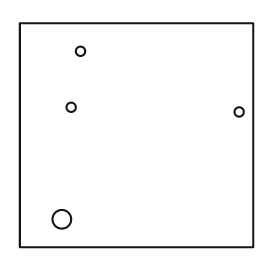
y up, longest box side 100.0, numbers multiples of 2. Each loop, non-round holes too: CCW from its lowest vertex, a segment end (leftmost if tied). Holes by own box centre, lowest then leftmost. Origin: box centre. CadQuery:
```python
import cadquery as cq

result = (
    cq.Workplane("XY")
    .moveTo(-50.0, -48.0)
    .lineTo(50.0, -48.0)
    .lineTo(50.0, 48.0)
    .lineTo(-50.0, 48.0)
    .close()
    .moveTo(-32.0, -36.0)
    .circle(4.0)
    .moveTo(44.0, 10.0)
    .circle(2.0)
    .moveTo(-28.0, 12.0)
    .circle(2.0)
    .moveTo(-24.0, 36.0)
    .circle(2.0)
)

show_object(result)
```